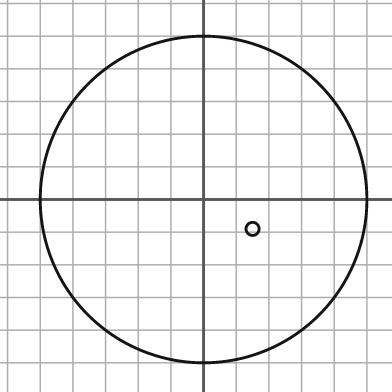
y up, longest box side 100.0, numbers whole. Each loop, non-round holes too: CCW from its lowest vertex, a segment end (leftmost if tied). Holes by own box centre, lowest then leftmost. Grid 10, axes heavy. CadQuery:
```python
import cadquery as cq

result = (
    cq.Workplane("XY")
    .moveTo(0.0, 0.0)
    .circle(50.0)
    .moveTo(15.0, -9.0)
    .circle(2.0)
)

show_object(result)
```